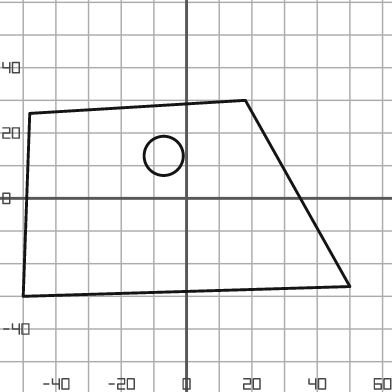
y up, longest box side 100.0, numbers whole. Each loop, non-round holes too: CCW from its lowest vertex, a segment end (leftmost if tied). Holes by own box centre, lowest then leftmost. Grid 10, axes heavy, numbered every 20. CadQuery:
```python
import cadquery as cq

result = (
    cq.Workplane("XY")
    .moveTo(-50.0, -30.0)
    .lineTo(50.0, -27.0)
    .lineTo(18.0, 30.0)
    .lineTo(-48.0, 26.0)
    .close()
    .moveTo(-7.0, 13.0)
    .circle(6.0)
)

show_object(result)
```